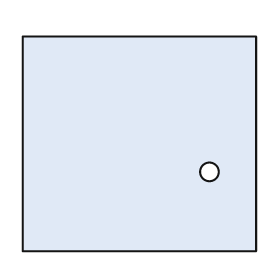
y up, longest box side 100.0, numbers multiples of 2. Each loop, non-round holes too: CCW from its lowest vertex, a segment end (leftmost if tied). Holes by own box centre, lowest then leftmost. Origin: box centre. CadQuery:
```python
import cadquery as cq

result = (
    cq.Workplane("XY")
    .moveTo(-50.0, -46.0)
    .lineTo(50.0, -46.0)
    .lineTo(50.0, 46.0)
    .lineTo(-50.0, 46.0)
    .close()
    .moveTo(30.0, -12.0)
    .circle(4.0)
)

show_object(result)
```